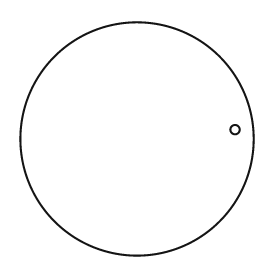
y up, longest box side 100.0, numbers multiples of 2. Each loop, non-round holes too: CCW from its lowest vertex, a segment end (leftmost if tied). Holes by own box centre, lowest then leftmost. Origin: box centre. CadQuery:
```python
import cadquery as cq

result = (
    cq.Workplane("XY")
    .moveTo(0.0, 0.0)
    .circle(50.0)
    .moveTo(42.0, 4.0)
    .circle(2.0)
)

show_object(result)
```